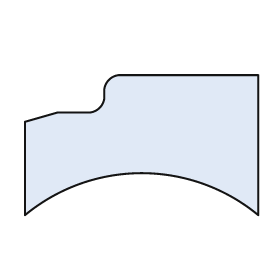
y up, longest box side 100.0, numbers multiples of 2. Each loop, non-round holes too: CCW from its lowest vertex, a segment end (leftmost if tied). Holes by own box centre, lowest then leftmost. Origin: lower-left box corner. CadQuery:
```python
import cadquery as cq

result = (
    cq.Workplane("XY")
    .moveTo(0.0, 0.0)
    .threePointArc((50.0, 18.0), (100.0, 0.0))
    .lineTo(100.0, 60.0)
    .lineTo(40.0, 60.0)
    .threePointArc((36.0, 58.0), (34.0, 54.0))
    .lineTo(34.0, 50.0)
    .threePointArc((32.0, 46.0), (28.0, 44.0))
    .lineTo(14.0, 44.0)
    .lineTo(0.0, 40.0)
    .close()
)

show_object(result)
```